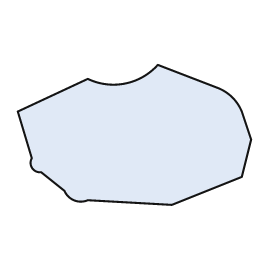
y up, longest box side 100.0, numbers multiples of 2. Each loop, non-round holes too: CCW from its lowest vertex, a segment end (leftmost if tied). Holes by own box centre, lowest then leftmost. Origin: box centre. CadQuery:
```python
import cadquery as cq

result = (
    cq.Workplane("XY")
    .moveTo(16.0, -30.0)
    .lineTo(46.0, -18.0)
    .lineTo(50.0, -2.0)
    .lineTo(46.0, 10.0)
    .threePointArc((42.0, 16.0), (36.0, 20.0))
    .lineTo(10.0, 30.0)
    .threePointArc((-4.0, 22.0), (-20.0, 24.0))
    .lineTo(-50.0, 10.0)
    .lineTo(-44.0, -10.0)
    .threePointArc((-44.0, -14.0), (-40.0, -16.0))
    .lineTo(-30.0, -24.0)
    .threePointArc((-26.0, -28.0), (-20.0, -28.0))
    .close()
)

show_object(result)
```